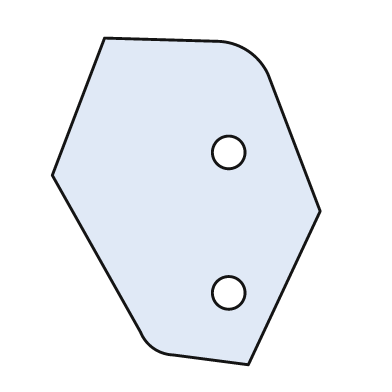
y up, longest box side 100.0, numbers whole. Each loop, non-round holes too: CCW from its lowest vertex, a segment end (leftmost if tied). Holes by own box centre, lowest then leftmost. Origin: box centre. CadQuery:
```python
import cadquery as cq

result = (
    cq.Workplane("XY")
    .moveTo(19.0, -50.0)
    .lineTo(41.0, -3.0)
    .lineTo(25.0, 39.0)
    .threePointArc((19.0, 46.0), (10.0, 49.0))
    .lineTo(-25.0, 50.0)
    .lineTo(-41.0, 8.0)
    .lineTo(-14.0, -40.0)
    .threePointArc((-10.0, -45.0), (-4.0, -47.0))
    .close()
    .moveTo(13.0, -28.0)
    .circle(5.0)
    .moveTo(13.0, 15.0)
    .circle(5.0)
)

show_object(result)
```